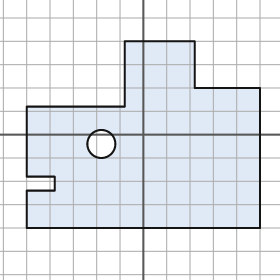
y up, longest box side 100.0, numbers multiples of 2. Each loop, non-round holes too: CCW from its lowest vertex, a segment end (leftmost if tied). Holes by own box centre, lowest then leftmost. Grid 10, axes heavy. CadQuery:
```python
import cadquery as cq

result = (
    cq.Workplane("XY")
    .moveTo(-50.0, -40.0)
    .lineTo(50.0, -40.0)
    .lineTo(50.0, 20.0)
    .lineTo(22.0, 20.0)
    .lineTo(22.0, 40.0)
    .lineTo(-8.0, 40.0)
    .lineTo(-8.0, 12.0)
    .lineTo(-50.0, 12.0)
    .lineTo(-50.0, -18.0)
    .lineTo(-38.0, -18.0)
    .lineTo(-38.0, -24.0)
    .lineTo(-50.0, -24.0)
    .close()
    .moveTo(-18.0, -4.0)
    .circle(6.0)
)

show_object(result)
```